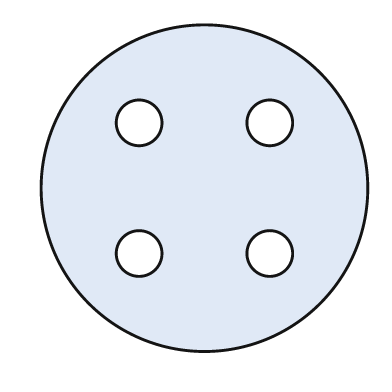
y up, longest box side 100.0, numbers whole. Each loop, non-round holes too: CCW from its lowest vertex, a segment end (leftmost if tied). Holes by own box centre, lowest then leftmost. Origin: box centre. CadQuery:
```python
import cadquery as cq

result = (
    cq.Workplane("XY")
    .moveTo(0.0, 0.0)
    .circle(50.0)
    .moveTo(-20.0, -20.0)
    .circle(7.0)
    .moveTo(20.0, -20.0)
    .circle(7.0)
    .moveTo(-20.0, 20.0)
    .circle(7.0)
    .moveTo(20.0, 20.0)
    .circle(7.0)
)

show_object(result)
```